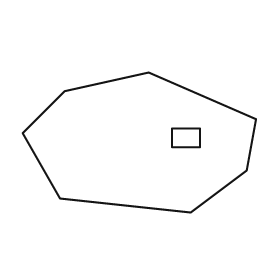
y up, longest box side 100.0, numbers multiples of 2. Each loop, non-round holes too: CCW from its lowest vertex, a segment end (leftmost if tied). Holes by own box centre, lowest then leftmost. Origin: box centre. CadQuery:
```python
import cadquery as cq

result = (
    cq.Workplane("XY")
    .moveTo(22.0, -30.0)
    .lineTo(46.0, -12.0)
    .lineTo(50.0, 10.0)
    .lineTo(4.0, 30.0)
    .lineTo(-32.0, 22.0)
    .lineTo(-50.0, 4.0)
    .lineTo(-34.0, -24.0)
    .close()
    .moveTo(14.0, -2.0)
    .lineTo(26.0, -2.0)
    .lineTo(26.0, 6.0)
    .lineTo(14.0, 6.0)
    .close()
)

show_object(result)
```